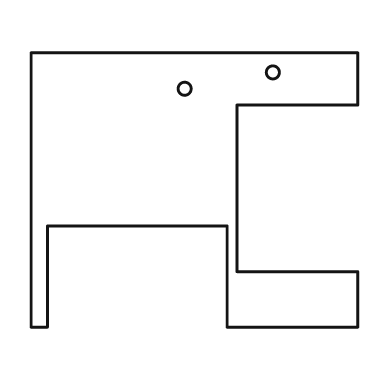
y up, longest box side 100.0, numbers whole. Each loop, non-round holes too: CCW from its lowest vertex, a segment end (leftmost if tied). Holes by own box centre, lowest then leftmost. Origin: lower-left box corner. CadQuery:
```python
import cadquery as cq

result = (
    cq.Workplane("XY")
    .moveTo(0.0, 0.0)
    .lineTo(5.0, 0.0)
    .lineTo(5.0, 31.0)
    .lineTo(60.0, 31.0)
    .lineTo(60.0, 0.0)
    .lineTo(100.0, 0.0)
    .lineTo(100.0, 17.0)
    .lineTo(63.0, 17.0)
    .lineTo(63.0, 68.0)
    .lineTo(100.0, 68.0)
    .lineTo(100.0, 84.0)
    .lineTo(0.0, 84.0)
    .close()
    .moveTo(47.0, 73.0)
    .circle(2.0)
    .moveTo(74.0, 78.0)
    .circle(2.0)
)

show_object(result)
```